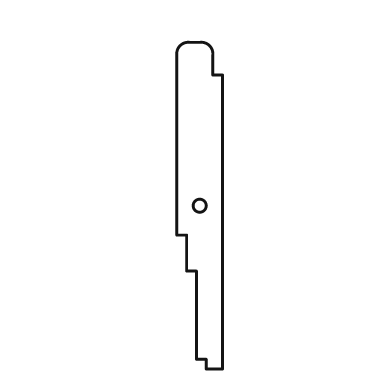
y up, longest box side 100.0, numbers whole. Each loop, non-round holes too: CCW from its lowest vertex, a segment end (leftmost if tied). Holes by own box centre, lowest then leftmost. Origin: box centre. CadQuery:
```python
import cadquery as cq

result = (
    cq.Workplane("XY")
    .moveTo(2.0, -50.0)
    .lineTo(7.0, -50.0)
    .lineTo(7.0, 40.0)
    .lineTo(4.0, 40.0)
    .lineTo(4.0, 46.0)
    .threePointArc((3.0, 49.0), (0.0, 50.0))
    .lineTo(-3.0, 50.0)
    .threePointArc((-6.0, 49.0), (-7.0, 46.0))
    .lineTo(-7.0, -9.0)
    .lineTo(-4.0, -9.0)
    .lineTo(-4.0, -20.0)
    .lineTo(-1.0, -20.0)
    .lineTo(-1.0, -47.0)
    .lineTo(2.0, -47.0)
    .close()
    .moveTo(0.0, 0.0)
    .circle(2.0)
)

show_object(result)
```